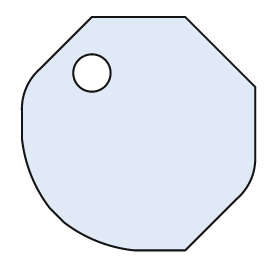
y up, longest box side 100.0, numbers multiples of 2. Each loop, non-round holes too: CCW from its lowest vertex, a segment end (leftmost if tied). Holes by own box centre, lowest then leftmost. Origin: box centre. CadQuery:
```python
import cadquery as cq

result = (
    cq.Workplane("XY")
    .moveTo(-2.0, -50.0)
    .lineTo(20.0, -50.0)
    .lineTo(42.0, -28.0)
    .threePointArc((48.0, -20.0), (50.0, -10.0))
    .lineTo(50.0, 20.0)
    .lineTo(20.0, 50.0)
    .lineTo(-20.0, 50.0)
    .lineTo(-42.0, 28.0)
    .threePointArc((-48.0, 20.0), (-50.0, 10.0))
    .lineTo(-50.0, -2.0)
    .threePointArc((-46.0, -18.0), (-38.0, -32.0))
    .lineTo(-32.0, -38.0)
    .threePointArc((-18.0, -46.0), (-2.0, -50.0))
    .close()
    .moveTo(-20.0, 26.0)
    .circle(8.0)
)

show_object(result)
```